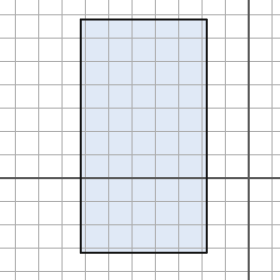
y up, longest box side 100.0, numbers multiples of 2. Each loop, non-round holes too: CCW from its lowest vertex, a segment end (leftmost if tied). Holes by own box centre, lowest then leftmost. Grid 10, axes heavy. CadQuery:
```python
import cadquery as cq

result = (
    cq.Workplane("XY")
    .moveTo(-72.0, -32.0)
    .lineTo(-18.0, -32.0)
    .lineTo(-18.0, 68.0)
    .lineTo(-72.0, 68.0)
    .close()
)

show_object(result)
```